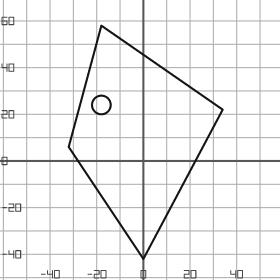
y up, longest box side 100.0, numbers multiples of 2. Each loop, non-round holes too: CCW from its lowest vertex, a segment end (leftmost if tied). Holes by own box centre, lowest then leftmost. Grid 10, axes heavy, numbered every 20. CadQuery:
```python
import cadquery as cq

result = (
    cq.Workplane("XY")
    .moveTo(0.0, -42.0)
    .lineTo(34.0, 22.0)
    .lineTo(-18.0, 58.0)
    .lineTo(-32.0, 6.0)
    .close()
    .moveTo(-18.0, 24.0)
    .circle(4.0)
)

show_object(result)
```